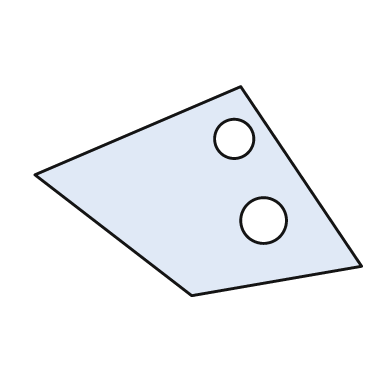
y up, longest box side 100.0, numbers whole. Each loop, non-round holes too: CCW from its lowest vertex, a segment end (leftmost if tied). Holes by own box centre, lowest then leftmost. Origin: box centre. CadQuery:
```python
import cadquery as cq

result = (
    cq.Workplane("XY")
    .moveTo(-2.0, -32.0)
    .lineTo(50.0, -23.0)
    .lineTo(13.0, 32.0)
    .lineTo(-50.0, 5.0)
    .close()
    .moveTo(20.0, -9.0)
    .circle(7.0)
    .moveTo(11.0, 16.0)
    .circle(6.0)
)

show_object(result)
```